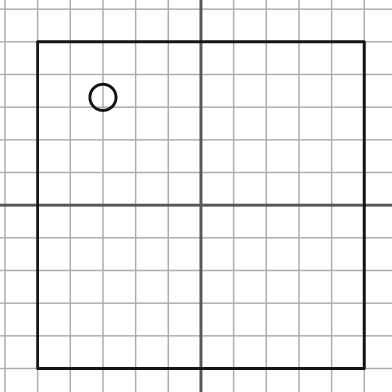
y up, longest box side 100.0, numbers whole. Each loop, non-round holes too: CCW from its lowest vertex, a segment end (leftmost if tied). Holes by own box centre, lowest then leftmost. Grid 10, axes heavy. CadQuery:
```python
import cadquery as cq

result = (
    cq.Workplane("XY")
    .moveTo(-50.0, -50.0)
    .lineTo(50.0, -50.0)
    .lineTo(50.0, 50.0)
    .lineTo(-50.0, 50.0)
    .close()
    .moveTo(-30.0, 33.0)
    .circle(4.0)
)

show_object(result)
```